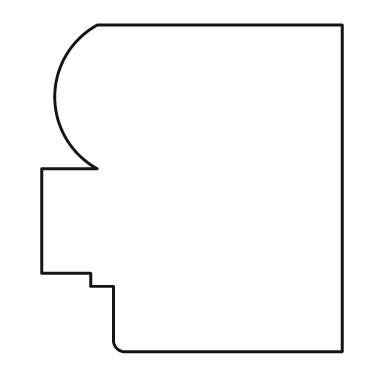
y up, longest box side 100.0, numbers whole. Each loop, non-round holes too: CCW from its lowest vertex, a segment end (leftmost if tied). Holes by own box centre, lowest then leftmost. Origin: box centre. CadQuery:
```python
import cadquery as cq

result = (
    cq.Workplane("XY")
    .moveTo(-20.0, -50.0)
    .lineTo(46.0, -50.0)
    .lineTo(46.0, 50.0)
    .lineTo(-29.0, 50.0)
    .threePointArc((-42.0, 28.0), (-29.0, 6.0))
    .lineTo(-46.0, 6.0)
    .lineTo(-46.0, -26.0)
    .lineTo(-31.0, -26.0)
    .lineTo(-31.0, -30.0)
    .lineTo(-24.0, -30.0)
    .lineTo(-24.0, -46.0)
    .threePointArc((-23.0, -49.0), (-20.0, -50.0))
    .close()
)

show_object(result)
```